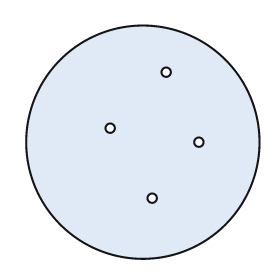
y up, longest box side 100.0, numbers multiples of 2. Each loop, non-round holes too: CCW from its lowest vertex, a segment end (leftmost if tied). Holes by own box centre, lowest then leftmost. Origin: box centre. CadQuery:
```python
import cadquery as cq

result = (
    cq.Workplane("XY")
    .moveTo(0.0, 0.0)
    .circle(50.0)
    .moveTo(4.0, -24.0)
    .circle(2.0)
    .moveTo(24.0, 0.0)
    .circle(2.0)
    .moveTo(-14.0, 6.0)
    .circle(2.0)
    .moveTo(10.0, 30.0)
    .circle(2.0)
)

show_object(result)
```